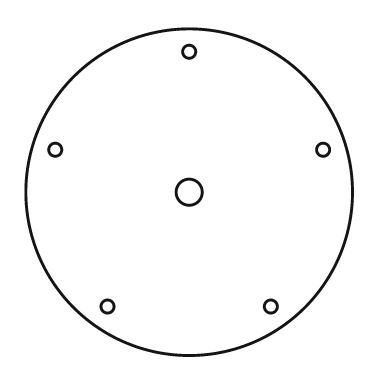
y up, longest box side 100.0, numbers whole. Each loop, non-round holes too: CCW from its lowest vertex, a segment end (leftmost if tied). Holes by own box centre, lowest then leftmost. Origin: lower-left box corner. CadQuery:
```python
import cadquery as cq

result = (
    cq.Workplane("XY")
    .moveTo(50.0, 50.0)
    .circle(50.0)
    .moveTo(25.0, 15.0)
    .circle(2.0)
    .moveTo(75.0, 15.0)
    .circle(2.0)
    .moveTo(50.0, 50.0)
    .circle(4.0)
    .moveTo(9.0, 63.0)
    .circle(2.0)
    .moveTo(91.0, 63.0)
    .circle(2.0)
    .moveTo(50.0, 93.0)
    .circle(2.0)
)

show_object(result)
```